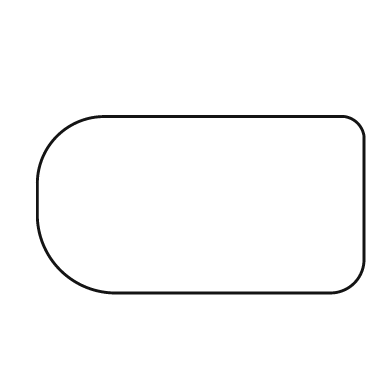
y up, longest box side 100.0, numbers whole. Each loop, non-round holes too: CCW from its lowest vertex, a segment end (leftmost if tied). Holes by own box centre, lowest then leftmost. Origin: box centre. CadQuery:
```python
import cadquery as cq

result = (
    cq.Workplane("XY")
    .moveTo(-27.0, -27.0)
    .lineTo(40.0, -27.0)
    .threePointArc((47.0, -24.0), (50.0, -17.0))
    .lineTo(50.0, 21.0)
    .threePointArc((48.0, 25.0), (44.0, 27.0))
    .lineTo(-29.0, 27.0)
    .threePointArc((-44.0, 21.0), (-50.0, 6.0))
    .lineTo(-50.0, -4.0)
    .threePointArc((-43.0, -20.0), (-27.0, -27.0))
    .close()
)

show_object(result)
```